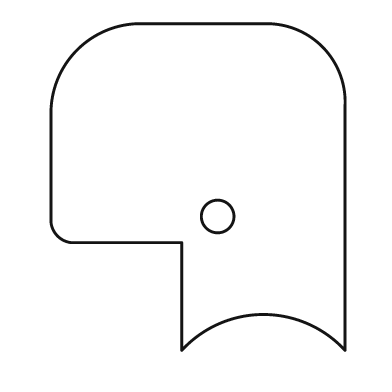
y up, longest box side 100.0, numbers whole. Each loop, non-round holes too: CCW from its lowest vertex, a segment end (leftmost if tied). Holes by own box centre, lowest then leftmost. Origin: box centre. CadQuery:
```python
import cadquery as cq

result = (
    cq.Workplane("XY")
    .moveTo(-5.0, -50.0)
    .threePointArc((20.0, -39.0), (45.0, -50.0))
    .lineTo(45.0, 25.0)
    .threePointArc((38.0, 43.0), (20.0, 50.0))
    .lineTo(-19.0, 50.0)
    .threePointArc((-37.0, 42.0), (-45.0, 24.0))
    .lineTo(-45.0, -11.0)
    .threePointArc((-43.0, -15.0), (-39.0, -17.0))
    .lineTo(-5.0, -17.0)
    .close()
    .moveTo(6.0, -9.0)
    .circle(5.0)
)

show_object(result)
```